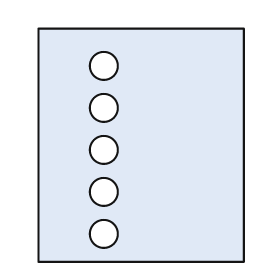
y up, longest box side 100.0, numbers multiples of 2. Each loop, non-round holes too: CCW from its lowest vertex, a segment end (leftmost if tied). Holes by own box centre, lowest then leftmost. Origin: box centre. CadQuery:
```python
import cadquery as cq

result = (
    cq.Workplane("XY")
    .moveTo(-44.0, -50.0)
    .lineTo(44.0, -50.0)
    .lineTo(44.0, 50.0)
    .lineTo(-44.0, 50.0)
    .close()
    .moveTo(-16.0, -38.0)
    .circle(6.0)
    .moveTo(-16.0, -20.0)
    .circle(6.0)
    .moveTo(-16.0, -2.0)
    .circle(6.0)
    .moveTo(-16.0, 16.0)
    .circle(6.0)
    .moveTo(-16.0, 34.0)
    .circle(6.0)
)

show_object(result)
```